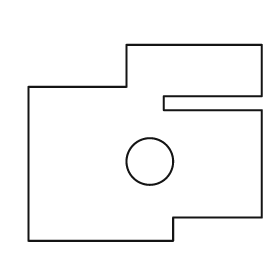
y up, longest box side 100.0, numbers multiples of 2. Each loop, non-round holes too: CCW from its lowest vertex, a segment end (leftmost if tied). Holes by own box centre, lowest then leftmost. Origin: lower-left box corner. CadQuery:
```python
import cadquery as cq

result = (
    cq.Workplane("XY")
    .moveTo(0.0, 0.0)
    .lineTo(62.0, 0.0)
    .lineTo(62.0, 10.0)
    .lineTo(100.0, 10.0)
    .lineTo(100.0, 56.0)
    .lineTo(58.0, 56.0)
    .lineTo(58.0, 62.0)
    .lineTo(100.0, 62.0)
    .lineTo(100.0, 84.0)
    .lineTo(42.0, 84.0)
    .lineTo(42.0, 66.0)
    .lineTo(0.0, 66.0)
    .close()
    .moveTo(52.0, 34.0)
    .circle(10.0)
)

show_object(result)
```